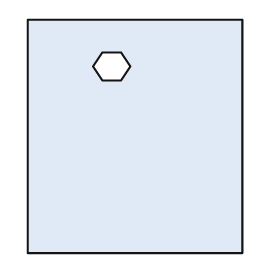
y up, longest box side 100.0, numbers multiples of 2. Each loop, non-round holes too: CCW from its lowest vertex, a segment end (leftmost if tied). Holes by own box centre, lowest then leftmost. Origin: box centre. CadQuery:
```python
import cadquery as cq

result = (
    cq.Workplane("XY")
    .moveTo(-46.0, -50.0)
    .lineTo(46.0, -50.0)
    .lineTo(46.0, 50.0)
    .lineTo(-46.0, 50.0)
    .close()
    .moveTo(-14.0, 24.0)
    .lineTo(-6.0, 24.0)
    .lineTo(-2.0, 30.0)
    .lineTo(-6.0, 36.0)
    .lineTo(-14.0, 36.0)
    .lineTo(-18.0, 30.0)
    .close()
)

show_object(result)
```